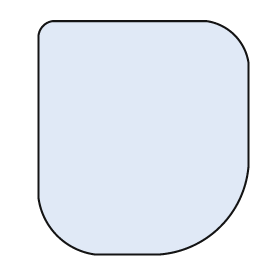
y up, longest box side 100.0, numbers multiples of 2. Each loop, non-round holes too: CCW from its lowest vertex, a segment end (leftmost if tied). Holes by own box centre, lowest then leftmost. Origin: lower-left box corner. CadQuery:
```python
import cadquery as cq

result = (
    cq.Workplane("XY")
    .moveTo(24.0, 0.0)
    .lineTo(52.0, 0.0)
    .threePointArc((78.0, 12.0), (90.0, 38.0))
    .lineTo(90.0, 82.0)
    .threePointArc((84.0, 94.0), (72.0, 100.0))
    .lineTo(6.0, 100.0)
    .threePointArc((2.0, 98.0), (0.0, 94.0))
    .lineTo(0.0, 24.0)
    .threePointArc((8.0, 8.0), (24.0, 0.0))
    .close()
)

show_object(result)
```